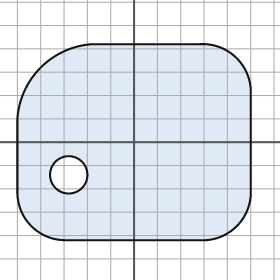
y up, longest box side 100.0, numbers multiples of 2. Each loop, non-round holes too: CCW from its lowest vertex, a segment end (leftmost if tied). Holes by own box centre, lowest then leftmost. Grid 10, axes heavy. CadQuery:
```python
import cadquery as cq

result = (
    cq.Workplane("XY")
    .moveTo(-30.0, -42.0)
    .lineTo(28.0, -42.0)
    .threePointArc((44.0, -36.0), (50.0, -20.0))
    .lineTo(50.0, 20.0)
    .threePointArc((44.0, 36.0), (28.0, 42.0))
    .lineTo(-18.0, 42.0)
    .threePointArc((-40.0, 32.0), (-50.0, 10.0))
    .lineTo(-50.0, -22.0)
    .threePointArc((-44.0, -36.0), (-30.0, -42.0))
    .close()
    .moveTo(-28.0, -14.0)
    .circle(8.0)
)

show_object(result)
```